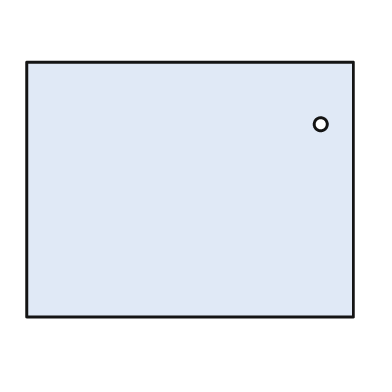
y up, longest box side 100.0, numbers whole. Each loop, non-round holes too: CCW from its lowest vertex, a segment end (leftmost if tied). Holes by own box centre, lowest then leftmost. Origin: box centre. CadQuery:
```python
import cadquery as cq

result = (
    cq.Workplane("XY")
    .moveTo(-50.0, -39.0)
    .lineTo(50.0, -39.0)
    .lineTo(50.0, 39.0)
    .lineTo(-50.0, 39.0)
    .close()
    .moveTo(40.0, 20.0)
    .circle(2.0)
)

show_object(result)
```